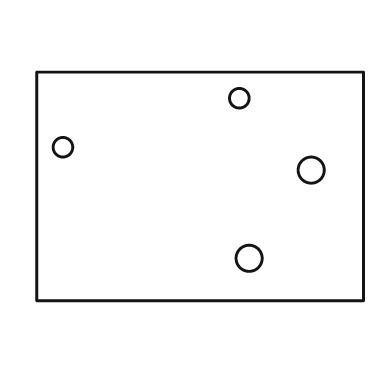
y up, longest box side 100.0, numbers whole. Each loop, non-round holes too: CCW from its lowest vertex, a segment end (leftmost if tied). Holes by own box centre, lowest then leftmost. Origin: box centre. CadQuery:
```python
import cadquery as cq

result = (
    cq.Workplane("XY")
    .moveTo(-50.0, -35.0)
    .lineTo(50.0, -35.0)
    .lineTo(50.0, 35.0)
    .lineTo(-50.0, 35.0)
    .close()
    .moveTo(15.0, -22.0)
    .circle(4.0)
    .moveTo(34.0, 5.0)
    .circle(4.0)
    .moveTo(-42.0, 12.0)
    .circle(3.0)
    .moveTo(12.0, 27.0)
    .circle(3.0)
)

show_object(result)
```